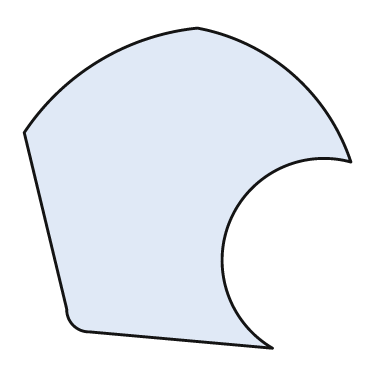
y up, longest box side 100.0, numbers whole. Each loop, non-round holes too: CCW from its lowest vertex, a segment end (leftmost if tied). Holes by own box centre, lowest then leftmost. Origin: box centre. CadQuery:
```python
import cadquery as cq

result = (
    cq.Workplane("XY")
    .moveTo(26.0, -49.0)
    .threePointArc((13.0, -10.0), (50.0, 8.0))
    .threePointArc((32.0, 35.0), (3.0, 49.0))
    .threePointArc((-27.0, 39.0), (-50.0, 17.0))
    .lineTo(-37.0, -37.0)
    .threePointArc((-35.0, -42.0), (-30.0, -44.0))
    .close()
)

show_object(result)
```